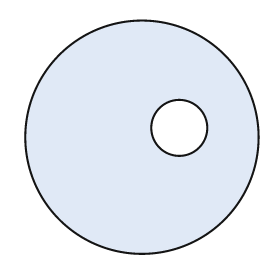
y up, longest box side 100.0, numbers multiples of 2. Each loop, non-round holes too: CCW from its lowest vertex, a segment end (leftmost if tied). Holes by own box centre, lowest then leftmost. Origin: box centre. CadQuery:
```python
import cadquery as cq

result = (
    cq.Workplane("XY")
    .moveTo(0.0, 0.0)
    .circle(50.0)
    .moveTo(16.0, 4.0)
    .circle(12.0)
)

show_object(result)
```